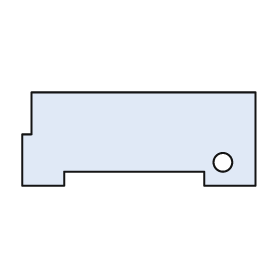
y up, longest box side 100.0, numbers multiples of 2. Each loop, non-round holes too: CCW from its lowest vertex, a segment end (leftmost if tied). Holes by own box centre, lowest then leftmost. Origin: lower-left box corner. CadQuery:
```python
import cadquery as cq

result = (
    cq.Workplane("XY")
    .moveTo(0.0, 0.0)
    .lineTo(18.0, 0.0)
    .lineTo(18.0, 6.0)
    .lineTo(78.0, 6.0)
    .lineTo(78.0, 0.0)
    .lineTo(100.0, 0.0)
    .lineTo(100.0, 40.0)
    .lineTo(4.0, 40.0)
    .lineTo(4.0, 22.0)
    .lineTo(0.0, 22.0)
    .close()
    .moveTo(86.0, 10.0)
    .circle(4.0)
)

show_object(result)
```